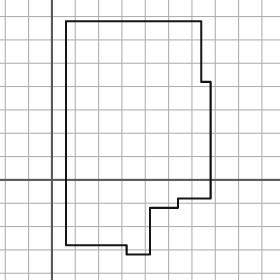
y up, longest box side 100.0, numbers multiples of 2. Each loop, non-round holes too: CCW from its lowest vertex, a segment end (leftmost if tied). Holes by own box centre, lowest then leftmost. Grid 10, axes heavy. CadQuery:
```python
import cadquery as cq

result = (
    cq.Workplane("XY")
    .moveTo(32.0, -32.0)
    .lineTo(42.0, -32.0)
    .lineTo(42.0, -12.0)
    .lineTo(54.0, -12.0)
    .lineTo(54.0, -8.0)
    .lineTo(68.0, -8.0)
    .lineTo(68.0, 42.0)
    .lineTo(64.0, 42.0)
    .lineTo(64.0, 68.0)
    .lineTo(6.0, 68.0)
    .lineTo(6.0, -28.0)
    .lineTo(32.0, -28.0)
    .close()
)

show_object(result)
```